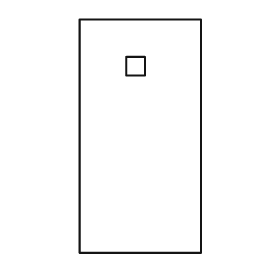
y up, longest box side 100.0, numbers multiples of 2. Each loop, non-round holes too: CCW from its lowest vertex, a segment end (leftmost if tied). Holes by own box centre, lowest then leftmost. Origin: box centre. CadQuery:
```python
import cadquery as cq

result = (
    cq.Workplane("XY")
    .moveTo(-26.0, -50.0)
    .lineTo(26.0, -50.0)
    .lineTo(26.0, 50.0)
    .lineTo(-26.0, 50.0)
    .close()
    .moveTo(-6.0, 26.0)
    .lineTo(2.0, 26.0)
    .lineTo(2.0, 34.0)
    .lineTo(-6.0, 34.0)
    .close()
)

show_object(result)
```